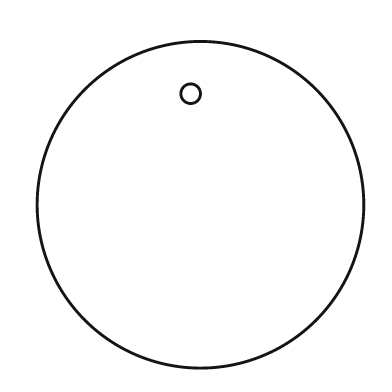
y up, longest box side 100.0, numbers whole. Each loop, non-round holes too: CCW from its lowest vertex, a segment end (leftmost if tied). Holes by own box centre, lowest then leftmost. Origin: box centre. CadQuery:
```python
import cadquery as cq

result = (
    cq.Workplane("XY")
    .moveTo(0.0, 0.0)
    .circle(50.0)
    .moveTo(-3.0, 34.0)
    .circle(3.0)
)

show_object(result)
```